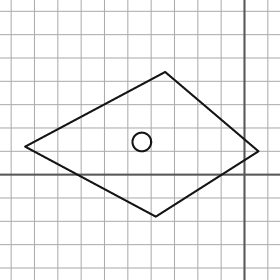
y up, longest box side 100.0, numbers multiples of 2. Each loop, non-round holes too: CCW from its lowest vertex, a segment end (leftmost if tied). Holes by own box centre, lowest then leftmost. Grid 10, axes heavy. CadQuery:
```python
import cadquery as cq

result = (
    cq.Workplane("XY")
    .moveTo(-38.0, -18.0)
    .lineTo(6.0, 10.0)
    .lineTo(-34.0, 44.0)
    .lineTo(-94.0, 12.0)
    .close()
    .moveTo(-44.0, 14.0)
    .circle(4.0)
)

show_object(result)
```